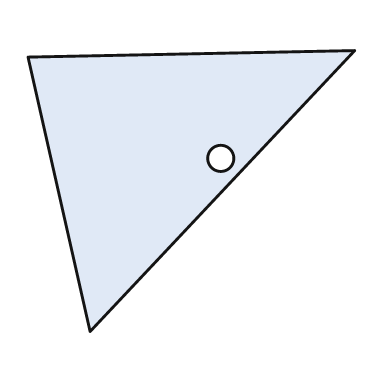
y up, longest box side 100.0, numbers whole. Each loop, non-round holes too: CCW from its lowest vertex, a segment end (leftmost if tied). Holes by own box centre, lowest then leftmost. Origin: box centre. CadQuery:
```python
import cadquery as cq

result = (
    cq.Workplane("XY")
    .moveTo(-31.0, -43.0)
    .lineTo(50.0, 43.0)
    .lineTo(-50.0, 41.0)
    .close()
    .moveTo(9.0, 10.0)
    .circle(4.0)
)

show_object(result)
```